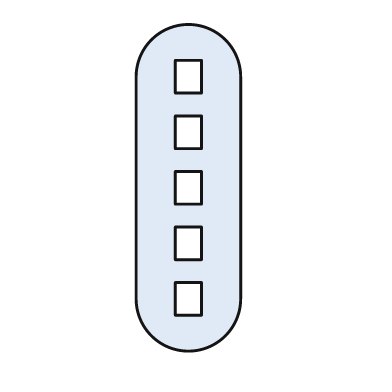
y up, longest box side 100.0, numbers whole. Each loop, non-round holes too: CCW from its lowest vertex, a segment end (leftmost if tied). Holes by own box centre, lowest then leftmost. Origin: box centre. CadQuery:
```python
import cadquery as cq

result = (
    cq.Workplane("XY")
    .moveTo(-16.0, -34.0)
    .threePointArc((0.0, -50.0), (16.0, -34.0))
    .lineTo(16.0, 34.0)
    .threePointArc((0.0, 50.0), (-16.0, 34.0))
    .close()
    .moveTo(-4.0, -39.0)
    .lineTo(4.0, -39.0)
    .lineTo(4.0, -29.0)
    .lineTo(-4.0, -29.0)
    .close()
    .moveTo(-4.0, -22.0)
    .lineTo(4.0, -22.0)
    .lineTo(4.0, -12.0)
    .lineTo(-4.0, -12.0)
    .close()
    .moveTo(-4.0, -5.0)
    .lineTo(4.0, -5.0)
    .lineTo(4.0, 5.0)
    .lineTo(-4.0, 5.0)
    .close()
    .moveTo(-4.0, 12.0)
    .lineTo(4.0, 12.0)
    .lineTo(4.0, 22.0)
    .lineTo(-4.0, 22.0)
    .close()
    .moveTo(-4.0, 29.0)
    .lineTo(4.0, 29.0)
    .lineTo(4.0, 39.0)
    .lineTo(-4.0, 39.0)
    .close()
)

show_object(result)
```